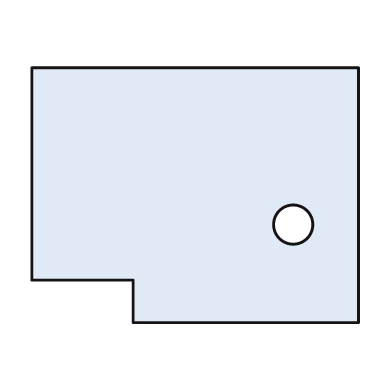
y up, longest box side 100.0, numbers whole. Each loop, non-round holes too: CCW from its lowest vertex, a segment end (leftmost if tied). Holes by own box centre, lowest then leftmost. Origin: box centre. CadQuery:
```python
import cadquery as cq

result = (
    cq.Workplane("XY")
    .moveTo(-19.0, -39.0)
    .lineTo(50.0, -39.0)
    .lineTo(50.0, 39.0)
    .lineTo(-50.0, 39.0)
    .lineTo(-50.0, -26.0)
    .lineTo(-19.0, -26.0)
    .close()
    .moveTo(30.0, -9.0)
    .circle(6.0)
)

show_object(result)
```